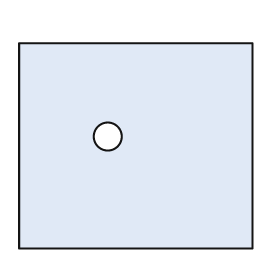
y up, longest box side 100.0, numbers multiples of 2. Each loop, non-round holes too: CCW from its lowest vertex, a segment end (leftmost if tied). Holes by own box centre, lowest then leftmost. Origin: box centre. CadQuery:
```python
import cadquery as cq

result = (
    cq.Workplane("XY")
    .moveTo(-50.0, -44.0)
    .lineTo(50.0, -44.0)
    .lineTo(50.0, 44.0)
    .lineTo(-50.0, 44.0)
    .close()
    .moveTo(-12.0, 4.0)
    .circle(6.0)
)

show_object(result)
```